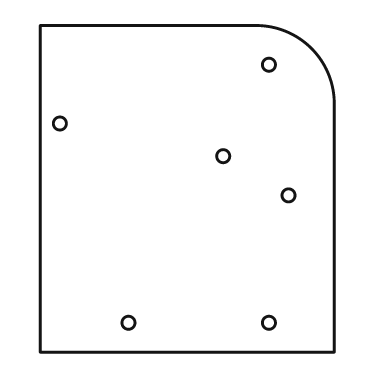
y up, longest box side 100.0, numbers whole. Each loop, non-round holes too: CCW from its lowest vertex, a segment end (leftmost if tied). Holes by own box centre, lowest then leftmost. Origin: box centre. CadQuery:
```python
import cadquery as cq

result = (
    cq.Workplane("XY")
    .moveTo(-45.0, -50.0)
    .lineTo(45.0, -50.0)
    .lineTo(45.0, 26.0)
    .threePointArc((38.0, 43.0), (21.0, 50.0))
    .lineTo(-45.0, 50.0)
    .close()
    .moveTo(-18.0, -41.0)
    .circle(2.0)
    .moveTo(25.0, -41.0)
    .circle(2.0)
    .moveTo(31.0, -2.0)
    .circle(2.0)
    .moveTo(11.0, 10.0)
    .circle(2.0)
    .moveTo(-39.0, 20.0)
    .circle(2.0)
    .moveTo(25.0, 38.0)
    .circle(2.0)
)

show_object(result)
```